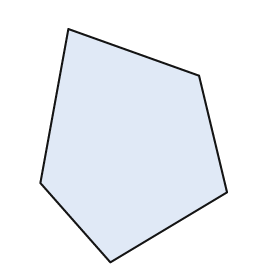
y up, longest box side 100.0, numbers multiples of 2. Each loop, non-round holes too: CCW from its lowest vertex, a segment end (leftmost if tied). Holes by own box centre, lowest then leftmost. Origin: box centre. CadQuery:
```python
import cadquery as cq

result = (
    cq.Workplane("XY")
    .moveTo(-10.0, -50.0)
    .lineTo(40.0, -20.0)
    .lineTo(28.0, 30.0)
    .lineTo(-28.0, 50.0)
    .lineTo(-40.0, -16.0)
    .close()
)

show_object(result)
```